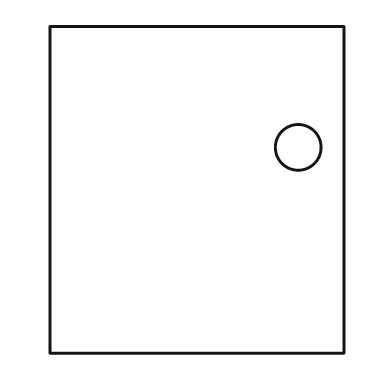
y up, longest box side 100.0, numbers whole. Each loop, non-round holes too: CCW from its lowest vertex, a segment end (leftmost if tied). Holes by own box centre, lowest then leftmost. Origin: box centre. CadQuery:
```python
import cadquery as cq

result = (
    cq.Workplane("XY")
    .moveTo(-45.0, -50.0)
    .lineTo(45.0, -50.0)
    .lineTo(45.0, 50.0)
    .lineTo(-45.0, 50.0)
    .close()
    .moveTo(31.0, 13.0)
    .circle(7.0)
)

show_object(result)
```